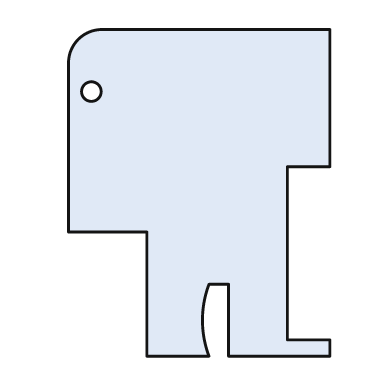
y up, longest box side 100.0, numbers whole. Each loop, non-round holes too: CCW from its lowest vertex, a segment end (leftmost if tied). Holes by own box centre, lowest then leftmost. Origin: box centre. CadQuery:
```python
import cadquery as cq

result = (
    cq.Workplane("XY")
    .moveTo(-16.0, -50.0)
    .lineTo(3.0, -50.0)
    .threePointArc((1.0, -39.0), (3.0, -28.0))
    .lineTo(9.0, -28.0)
    .lineTo(9.0, -50.0)
    .lineTo(40.0, -50.0)
    .lineTo(40.0, -45.0)
    .lineTo(27.0, -45.0)
    .lineTo(27.0, 8.0)
    .lineTo(40.0, 8.0)
    .lineTo(40.0, 50.0)
    .lineTo(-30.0, 50.0)
    .threePointArc((-37.0, 47.0), (-40.0, 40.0))
    .lineTo(-40.0, -12.0)
    .lineTo(-16.0, -12.0)
    .close()
    .moveTo(-33.0, 31.0)
    .circle(3.0)
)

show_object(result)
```